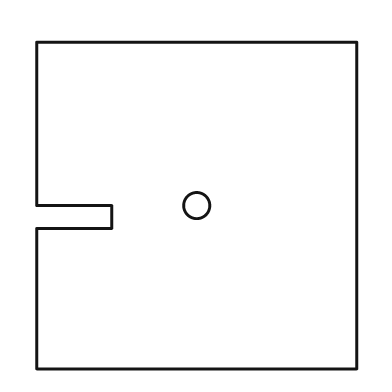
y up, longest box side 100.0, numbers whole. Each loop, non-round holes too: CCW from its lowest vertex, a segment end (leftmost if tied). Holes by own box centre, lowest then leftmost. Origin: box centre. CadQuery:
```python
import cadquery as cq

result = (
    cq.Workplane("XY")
    .moveTo(-49.0, -50.0)
    .lineTo(49.0, -50.0)
    .lineTo(49.0, 50.0)
    .lineTo(-49.0, 50.0)
    .lineTo(-49.0, 0.0)
    .lineTo(-26.0, 0.0)
    .lineTo(-26.0, -7.0)
    .lineTo(-49.0, -7.0)
    .close()
    .moveTo(0.0, 0.0)
    .circle(4.0)
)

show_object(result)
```